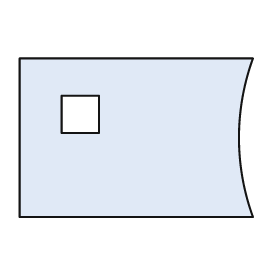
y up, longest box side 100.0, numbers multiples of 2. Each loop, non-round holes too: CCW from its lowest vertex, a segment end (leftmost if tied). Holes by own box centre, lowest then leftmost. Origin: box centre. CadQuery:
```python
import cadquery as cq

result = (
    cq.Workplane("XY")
    .moveTo(-50.0, -34.0)
    .lineTo(50.0, -34.0)
    .threePointArc((44.0, 0.0), (50.0, 34.0))
    .lineTo(-50.0, 34.0)
    .close()
    .moveTo(-32.0, 2.0)
    .lineTo(-16.0, 2.0)
    .lineTo(-16.0, 18.0)
    .lineTo(-32.0, 18.0)
    .close()
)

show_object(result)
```